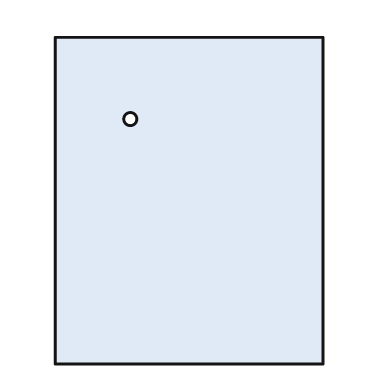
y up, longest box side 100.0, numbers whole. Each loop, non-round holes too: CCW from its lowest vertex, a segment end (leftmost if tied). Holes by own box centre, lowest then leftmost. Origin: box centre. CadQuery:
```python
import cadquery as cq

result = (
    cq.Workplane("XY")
    .moveTo(-41.0, -50.0)
    .lineTo(41.0, -50.0)
    .lineTo(41.0, 50.0)
    .lineTo(-41.0, 50.0)
    .close()
    .moveTo(-18.0, 25.0)
    .circle(2.0)
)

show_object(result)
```